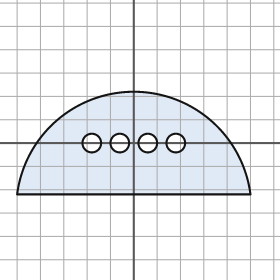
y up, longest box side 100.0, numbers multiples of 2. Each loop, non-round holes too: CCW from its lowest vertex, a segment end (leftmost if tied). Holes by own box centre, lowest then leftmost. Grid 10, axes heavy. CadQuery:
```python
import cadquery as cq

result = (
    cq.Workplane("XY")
    .moveTo(-50.0, -22.0)
    .lineTo(50.0, -22.0)
    .threePointArc((0.0, 22.0), (-50.0, -22.0))
    .close()
    .moveTo(-18.0, 0.0)
    .circle(4.0)
    .moveTo(-6.0, 0.0)
    .circle(4.0)
    .moveTo(6.0, 0.0)
    .circle(4.0)
    .moveTo(18.0, 0.0)
    .circle(4.0)
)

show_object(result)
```